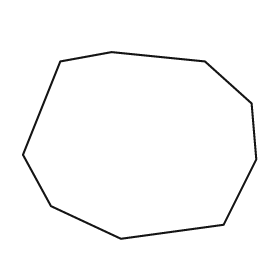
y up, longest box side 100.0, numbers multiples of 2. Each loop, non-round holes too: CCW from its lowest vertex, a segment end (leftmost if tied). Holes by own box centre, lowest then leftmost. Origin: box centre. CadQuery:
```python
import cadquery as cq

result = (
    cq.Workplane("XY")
    .moveTo(-8.0, -40.0)
    .lineTo(36.0, -34.0)
    .lineTo(50.0, -6.0)
    .lineTo(48.0, 18.0)
    .lineTo(28.0, 36.0)
    .lineTo(-12.0, 40.0)
    .lineTo(-34.0, 36.0)
    .lineTo(-50.0, -4.0)
    .lineTo(-38.0, -26.0)
    .close()
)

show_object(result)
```